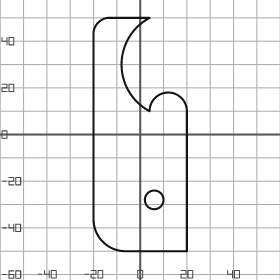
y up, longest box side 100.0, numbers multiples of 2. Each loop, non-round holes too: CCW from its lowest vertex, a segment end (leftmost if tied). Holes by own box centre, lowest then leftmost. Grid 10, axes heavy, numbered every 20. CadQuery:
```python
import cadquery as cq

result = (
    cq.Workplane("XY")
    .moveTo(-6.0, -50.0)
    .lineTo(20.0, -50.0)
    .lineTo(20.0, 10.0)
    .threePointArc((12.0, 18.0), (4.0, 10.0))
    .threePointArc((-8.0, 30.0), (4.0, 50.0))
    .lineTo(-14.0, 50.0)
    .threePointArc((-18.0, 48.0), (-20.0, 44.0))
    .lineTo(-20.0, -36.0)
    .threePointArc((-16.0, -46.0), (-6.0, -50.0))
    .close()
    .moveTo(6.0, -28.0)
    .circle(4.0)
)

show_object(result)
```